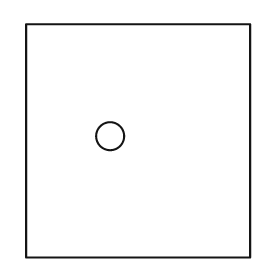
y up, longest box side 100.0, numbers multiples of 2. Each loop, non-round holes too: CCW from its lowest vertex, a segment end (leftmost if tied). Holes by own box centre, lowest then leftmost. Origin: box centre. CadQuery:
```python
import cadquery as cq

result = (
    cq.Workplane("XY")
    .moveTo(-48.0, -50.0)
    .lineTo(48.0, -50.0)
    .lineTo(48.0, 50.0)
    .lineTo(-48.0, 50.0)
    .close()
    .moveTo(-12.0, 2.0)
    .circle(6.0)
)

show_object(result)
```